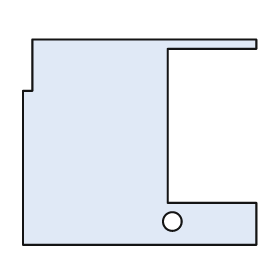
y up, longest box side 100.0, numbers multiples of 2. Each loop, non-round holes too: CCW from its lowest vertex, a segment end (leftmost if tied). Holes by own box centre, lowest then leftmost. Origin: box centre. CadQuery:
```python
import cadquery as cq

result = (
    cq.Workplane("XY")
    .moveTo(-50.0, -44.0)
    .lineTo(50.0, -44.0)
    .lineTo(50.0, -26.0)
    .lineTo(12.0, -26.0)
    .lineTo(12.0, 40.0)
    .lineTo(50.0, 40.0)
    .lineTo(50.0, 44.0)
    .lineTo(-46.0, 44.0)
    .lineTo(-46.0, 22.0)
    .lineTo(-50.0, 22.0)
    .close()
    .moveTo(14.0, -34.0)
    .circle(4.0)
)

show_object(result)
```